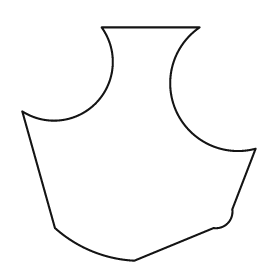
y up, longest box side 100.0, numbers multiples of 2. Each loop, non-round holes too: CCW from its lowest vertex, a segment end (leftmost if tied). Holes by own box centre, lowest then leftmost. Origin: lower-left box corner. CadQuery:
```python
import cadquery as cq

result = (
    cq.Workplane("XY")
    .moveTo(48.0, 0.0)
    .lineTo(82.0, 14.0)
    .threePointArc((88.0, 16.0), (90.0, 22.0))
    .lineTo(100.0, 48.0)
    .threePointArc((66.0, 64.0), (76.0, 100.0))
    .lineTo(34.0, 100.0)
    .threePointArc((32.0, 68.0), (0.0, 64.0))
    .lineTo(14.0, 14.0)
    .threePointArc((30.0, 4.0), (48.0, 0.0))
    .close()
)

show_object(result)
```